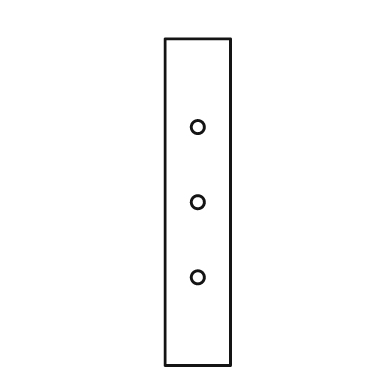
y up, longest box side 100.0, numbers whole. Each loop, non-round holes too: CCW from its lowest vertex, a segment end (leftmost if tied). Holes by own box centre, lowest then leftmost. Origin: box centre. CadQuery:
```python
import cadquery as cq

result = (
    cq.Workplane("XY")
    .moveTo(-10.0, -50.0)
    .lineTo(10.0, -50.0)
    .lineTo(10.0, 50.0)
    .lineTo(-10.0, 50.0)
    .close()
    .moveTo(0.0, -23.0)
    .circle(2.0)
    .moveTo(0.0, 0.0)
    .circle(2.0)
    .moveTo(0.0, 23.0)
    .circle(2.0)
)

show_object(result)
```